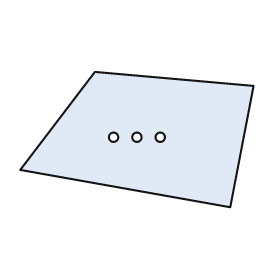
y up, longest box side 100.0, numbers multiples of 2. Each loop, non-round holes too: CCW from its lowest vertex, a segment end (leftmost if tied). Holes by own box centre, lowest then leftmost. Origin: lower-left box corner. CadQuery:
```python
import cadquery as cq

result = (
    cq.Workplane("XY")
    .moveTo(90.0, 0.0)
    .lineTo(100.0, 52.0)
    .lineTo(32.0, 58.0)
    .lineTo(0.0, 16.0)
    .close()
    .moveTo(40.0, 30.0)
    .circle(2.0)
    .moveTo(50.0, 30.0)
    .circle(2.0)
    .moveTo(60.0, 30.0)
    .circle(2.0)
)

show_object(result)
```